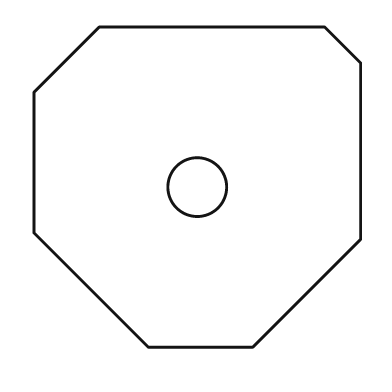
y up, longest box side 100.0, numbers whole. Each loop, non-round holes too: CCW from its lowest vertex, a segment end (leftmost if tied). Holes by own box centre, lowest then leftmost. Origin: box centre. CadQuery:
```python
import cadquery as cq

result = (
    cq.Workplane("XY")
    .moveTo(-15.0, -49.0)
    .lineTo(17.0, -49.0)
    .lineTo(50.0, -16.0)
    .lineTo(50.0, 38.0)
    .lineTo(39.0, 49.0)
    .lineTo(-30.0, 49.0)
    .lineTo(-50.0, 29.0)
    .lineTo(-50.0, -14.0)
    .close()
    .moveTo(0.0, 0.0)
    .circle(9.0)
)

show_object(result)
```